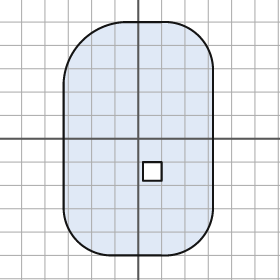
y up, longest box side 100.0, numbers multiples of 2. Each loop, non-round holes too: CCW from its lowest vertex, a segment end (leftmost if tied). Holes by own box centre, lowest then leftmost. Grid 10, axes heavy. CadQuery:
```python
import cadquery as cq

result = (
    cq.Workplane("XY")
    .moveTo(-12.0, -50.0)
    .lineTo(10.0, -50.0)
    .threePointArc((26.0, -44.0), (32.0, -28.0))
    .lineTo(32.0, 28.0)
    .threePointArc((26.0, 44.0), (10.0, 50.0))
    .lineTo(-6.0, 50.0)
    .threePointArc((-24.0, 42.0), (-32.0, 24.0))
    .lineTo(-32.0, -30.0)
    .threePointArc((-26.0, -44.0), (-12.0, -50.0))
    .close()
    .moveTo(2.0, -18.0)
    .lineTo(10.0, -18.0)
    .lineTo(10.0, -10.0)
    .lineTo(2.0, -10.0)
    .close()
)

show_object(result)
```